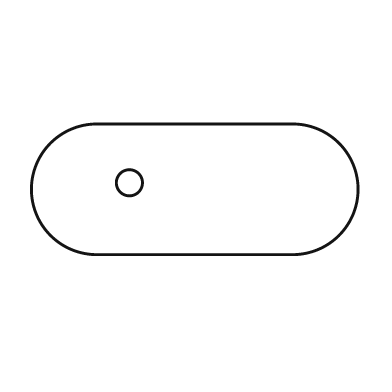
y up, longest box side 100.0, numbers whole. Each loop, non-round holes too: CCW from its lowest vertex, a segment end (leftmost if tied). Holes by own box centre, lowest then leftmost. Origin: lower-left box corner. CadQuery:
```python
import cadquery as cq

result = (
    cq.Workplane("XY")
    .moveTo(20.0, 0.0)
    .lineTo(80.0, 0.0)
    .threePointArc((100.0, 20.0), (80.0, 40.0))
    .lineTo(20.0, 40.0)
    .threePointArc((0.0, 20.0), (20.0, 0.0))
    .close()
    .moveTo(30.0, 22.0)
    .circle(4.0)
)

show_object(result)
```